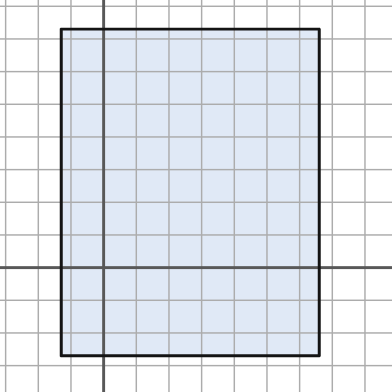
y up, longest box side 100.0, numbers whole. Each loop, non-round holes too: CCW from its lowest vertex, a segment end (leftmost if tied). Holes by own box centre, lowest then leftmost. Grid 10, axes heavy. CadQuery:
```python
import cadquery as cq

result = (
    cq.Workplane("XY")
    .moveTo(-13.0, -27.0)
    .lineTo(66.0, -27.0)
    .lineTo(66.0, 73.0)
    .lineTo(-13.0, 73.0)
    .close()
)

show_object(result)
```